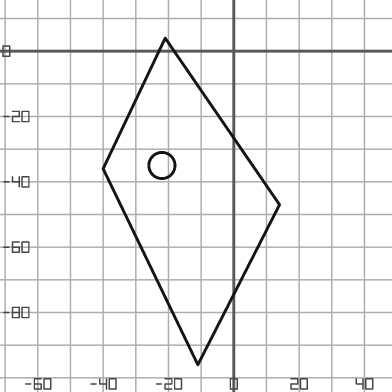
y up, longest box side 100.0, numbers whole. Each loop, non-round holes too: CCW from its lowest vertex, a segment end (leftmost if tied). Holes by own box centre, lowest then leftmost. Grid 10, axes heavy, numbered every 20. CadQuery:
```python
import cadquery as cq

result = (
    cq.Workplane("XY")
    .moveTo(-11.0, -96.0)
    .lineTo(14.0, -47.0)
    .lineTo(-21.0, 4.0)
    .lineTo(-40.0, -36.0)
    .close()
    .moveTo(-22.0, -35.0)
    .circle(4.0)
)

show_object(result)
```